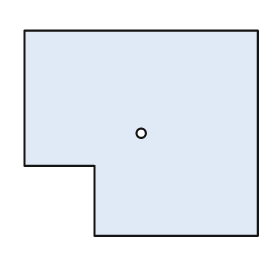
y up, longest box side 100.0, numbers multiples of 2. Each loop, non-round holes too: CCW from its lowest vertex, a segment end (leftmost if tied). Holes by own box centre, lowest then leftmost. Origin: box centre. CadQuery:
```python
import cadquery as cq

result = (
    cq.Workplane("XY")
    .moveTo(-20.0, -44.0)
    .lineTo(50.0, -44.0)
    .lineTo(50.0, 44.0)
    .lineTo(-50.0, 44.0)
    .lineTo(-50.0, -14.0)
    .lineTo(-20.0, -14.0)
    .close()
    .moveTo(0.0, 0.0)
    .circle(2.0)
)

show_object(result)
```